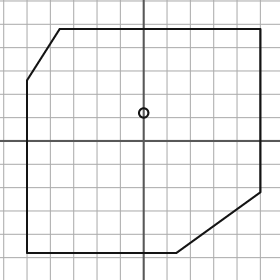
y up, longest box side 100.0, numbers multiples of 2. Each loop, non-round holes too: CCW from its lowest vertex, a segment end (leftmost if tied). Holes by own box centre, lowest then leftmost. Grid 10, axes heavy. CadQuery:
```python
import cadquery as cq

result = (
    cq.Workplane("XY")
    .moveTo(-50.0, -48.0)
    .lineTo(14.0, -48.0)
    .lineTo(50.0, -22.0)
    .lineTo(50.0, 48.0)
    .lineTo(-36.0, 48.0)
    .lineTo(-50.0, 26.0)
    .close()
    .moveTo(0.0, 12.0)
    .circle(2.0)
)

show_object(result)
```